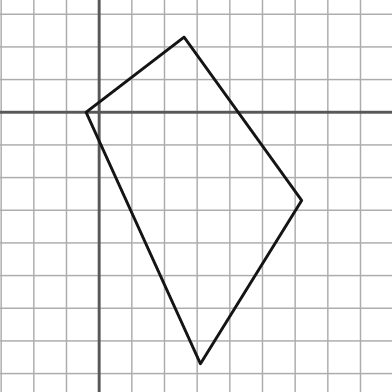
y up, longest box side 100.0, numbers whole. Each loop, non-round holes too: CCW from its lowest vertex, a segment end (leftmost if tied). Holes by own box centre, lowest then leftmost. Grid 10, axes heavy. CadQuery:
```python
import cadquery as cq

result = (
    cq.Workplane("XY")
    .moveTo(31.0, -77.0)
    .lineTo(62.0, -27.0)
    .lineTo(26.0, 23.0)
    .lineTo(-4.0, 0.0)
    .close()
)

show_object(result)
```